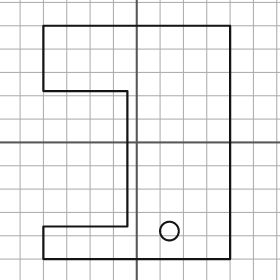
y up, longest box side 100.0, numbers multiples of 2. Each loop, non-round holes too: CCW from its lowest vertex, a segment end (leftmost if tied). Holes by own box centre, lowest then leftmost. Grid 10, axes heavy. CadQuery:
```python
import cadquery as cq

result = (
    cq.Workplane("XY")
    .moveTo(-40.0, -50.0)
    .lineTo(40.0, -50.0)
    .lineTo(40.0, 50.0)
    .lineTo(-40.0, 50.0)
    .lineTo(-40.0, 22.0)
    .lineTo(-4.0, 22.0)
    .lineTo(-4.0, -36.0)
    .lineTo(-40.0, -36.0)
    .close()
    .moveTo(14.0, -38.0)
    .circle(4.0)
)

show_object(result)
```